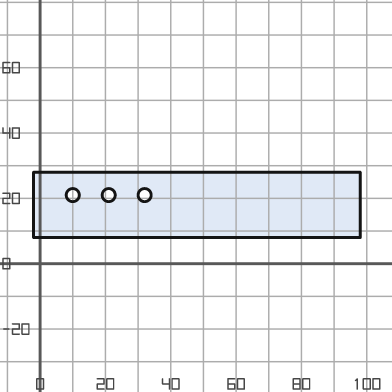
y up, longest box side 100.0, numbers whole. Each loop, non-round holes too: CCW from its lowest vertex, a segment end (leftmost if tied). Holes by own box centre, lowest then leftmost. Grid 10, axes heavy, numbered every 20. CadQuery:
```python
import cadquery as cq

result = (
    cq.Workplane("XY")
    .moveTo(-2.0, 8.0)
    .lineTo(98.0, 8.0)
    .lineTo(98.0, 28.0)
    .lineTo(-2.0, 28.0)
    .close()
    .moveTo(10.0, 21.0)
    .circle(2.0)
    .moveTo(21.0, 21.0)
    .circle(2.0)
    .moveTo(32.0, 21.0)
    .circle(2.0)
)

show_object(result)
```